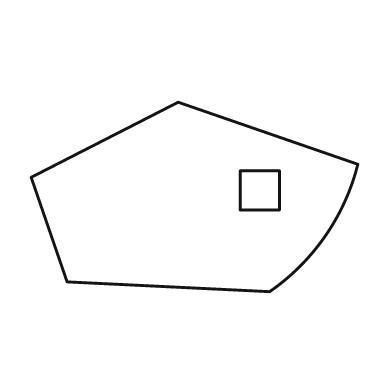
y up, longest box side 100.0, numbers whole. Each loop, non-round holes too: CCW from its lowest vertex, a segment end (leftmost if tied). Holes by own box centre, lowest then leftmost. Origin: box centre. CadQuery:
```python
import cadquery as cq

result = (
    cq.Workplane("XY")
    .moveTo(23.0, -29.0)
    .threePointArc((40.0, -12.0), (50.0, 10.0))
    .lineTo(-5.0, 29.0)
    .lineTo(-50.0, 6.0)
    .lineTo(-39.0, -26.0)
    .close()
    .moveTo(14.0, -4.0)
    .lineTo(26.0, -4.0)
    .lineTo(26.0, 8.0)
    .lineTo(14.0, 8.0)
    .close()
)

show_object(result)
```